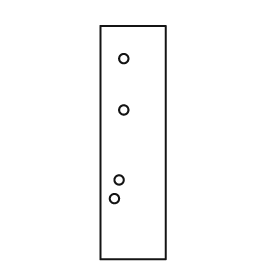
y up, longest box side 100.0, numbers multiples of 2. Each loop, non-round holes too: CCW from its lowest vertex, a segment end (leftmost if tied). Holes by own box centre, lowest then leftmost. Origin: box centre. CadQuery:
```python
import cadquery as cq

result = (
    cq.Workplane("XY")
    .moveTo(-14.0, -50.0)
    .lineTo(14.0, -50.0)
    .lineTo(14.0, 50.0)
    .lineTo(-14.0, 50.0)
    .close()
    .moveTo(-8.0, -24.0)
    .circle(2.0)
    .moveTo(-6.0, -16.0)
    .circle(2.0)
    .moveTo(-4.0, 14.0)
    .circle(2.0)
    .moveTo(-4.0, 36.0)
    .circle(2.0)
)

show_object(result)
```